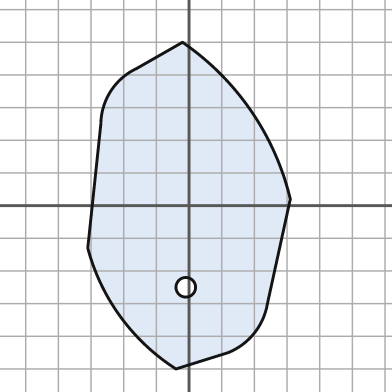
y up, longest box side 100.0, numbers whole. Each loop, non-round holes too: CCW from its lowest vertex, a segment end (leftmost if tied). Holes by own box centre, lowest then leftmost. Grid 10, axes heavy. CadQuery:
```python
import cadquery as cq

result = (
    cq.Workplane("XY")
    .moveTo(-4.0, -50.0)
    .lineTo(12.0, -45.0)
    .threePointArc((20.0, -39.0), (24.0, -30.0))
    .lineTo(31.0, 2.0)
    .threePointArc((19.0, 29.0), (-2.0, 50.0))
    .lineTo(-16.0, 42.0)
    .threePointArc((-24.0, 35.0), (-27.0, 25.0))
    .lineTo(-31.0, -13.0)
    .threePointArc((-21.0, -34.0), (-4.0, -50.0))
    .close()
    .moveTo(-1.0, -25.0)
    .circle(3.0)
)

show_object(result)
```